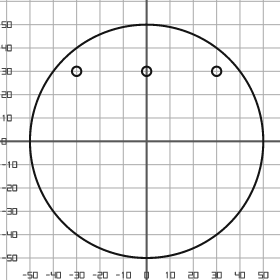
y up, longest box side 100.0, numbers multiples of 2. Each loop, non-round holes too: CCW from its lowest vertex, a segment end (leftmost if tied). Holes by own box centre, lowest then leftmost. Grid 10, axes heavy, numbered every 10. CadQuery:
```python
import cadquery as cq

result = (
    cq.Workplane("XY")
    .moveTo(0.0, 0.0)
    .circle(50.0)
    .moveTo(-30.0, 30.0)
    .circle(2.0)
    .moveTo(0.0, 30.0)
    .circle(2.0)
    .moveTo(30.0, 30.0)
    .circle(2.0)
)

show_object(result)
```